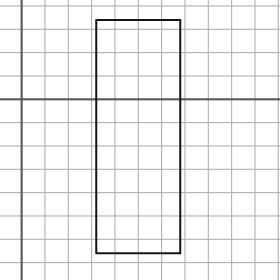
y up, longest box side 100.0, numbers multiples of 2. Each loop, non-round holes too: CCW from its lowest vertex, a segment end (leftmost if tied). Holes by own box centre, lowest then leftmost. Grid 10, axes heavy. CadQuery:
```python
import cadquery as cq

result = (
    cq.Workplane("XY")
    .moveTo(32.0, -66.0)
    .lineTo(68.0, -66.0)
    .lineTo(68.0, 34.0)
    .lineTo(32.0, 34.0)
    .close()
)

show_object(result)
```